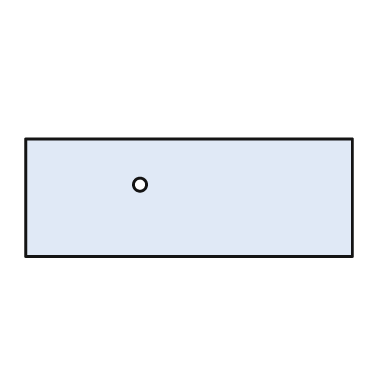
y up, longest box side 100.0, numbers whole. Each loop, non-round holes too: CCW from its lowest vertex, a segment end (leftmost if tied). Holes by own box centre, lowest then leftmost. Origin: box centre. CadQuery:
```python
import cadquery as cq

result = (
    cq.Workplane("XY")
    .moveTo(-50.0, -18.0)
    .lineTo(50.0, -18.0)
    .lineTo(50.0, 18.0)
    .lineTo(-50.0, 18.0)
    .close()
    .moveTo(-15.0, 4.0)
    .circle(2.0)
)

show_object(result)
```